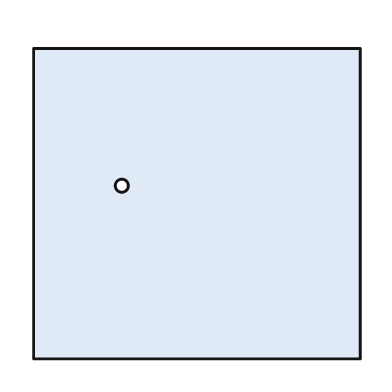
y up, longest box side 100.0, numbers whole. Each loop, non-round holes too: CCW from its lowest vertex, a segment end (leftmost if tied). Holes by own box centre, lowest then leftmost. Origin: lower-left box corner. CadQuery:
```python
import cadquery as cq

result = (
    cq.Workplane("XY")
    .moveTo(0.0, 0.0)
    .lineTo(100.0, 0.0)
    .lineTo(100.0, 95.0)
    .lineTo(0.0, 95.0)
    .close()
    .moveTo(27.0, 53.0)
    .circle(2.0)
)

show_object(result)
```